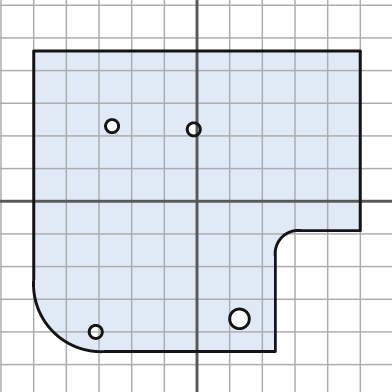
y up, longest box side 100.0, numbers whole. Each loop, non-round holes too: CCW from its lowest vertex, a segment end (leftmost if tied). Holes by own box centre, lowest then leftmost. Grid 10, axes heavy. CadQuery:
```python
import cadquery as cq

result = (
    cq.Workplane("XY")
    .moveTo(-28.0, -46.0)
    .lineTo(24.0, -46.0)
    .lineTo(24.0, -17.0)
    .threePointArc((26.0, -11.0), (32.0, -9.0))
    .lineTo(50.0, -9.0)
    .lineTo(50.0, 46.0)
    .lineTo(-50.0, 46.0)
    .lineTo(-50.0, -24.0)
    .threePointArc((-44.0, -40.0), (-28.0, -46.0))
    .close()
    .moveTo(-31.0, -40.0)
    .circle(2.0)
    .moveTo(13.0, -36.0)
    .circle(3.0)
    .moveTo(-1.0, 22.0)
    .circle(2.0)
    .moveTo(-26.0, 23.0)
    .circle(2.0)
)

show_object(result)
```